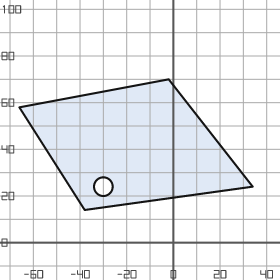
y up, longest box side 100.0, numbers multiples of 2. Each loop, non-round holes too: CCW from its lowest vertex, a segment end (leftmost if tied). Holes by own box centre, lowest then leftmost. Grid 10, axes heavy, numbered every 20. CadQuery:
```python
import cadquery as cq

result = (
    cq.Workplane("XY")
    .moveTo(-38.0, 14.0)
    .lineTo(34.0, 24.0)
    .lineTo(-2.0, 70.0)
    .lineTo(-66.0, 58.0)
    .close()
    .moveTo(-30.0, 24.0)
    .circle(4.0)
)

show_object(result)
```